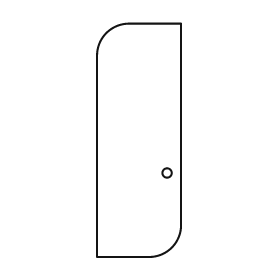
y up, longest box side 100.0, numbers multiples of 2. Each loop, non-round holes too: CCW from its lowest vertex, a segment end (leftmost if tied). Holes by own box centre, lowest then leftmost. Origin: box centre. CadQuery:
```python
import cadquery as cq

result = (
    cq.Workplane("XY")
    .moveTo(-18.0, -50.0)
    .lineTo(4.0, -50.0)
    .threePointArc((14.0, -46.0), (18.0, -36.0))
    .lineTo(18.0, 50.0)
    .lineTo(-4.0, 50.0)
    .threePointArc((-14.0, 46.0), (-18.0, 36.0))
    .close()
    .moveTo(12.0, -14.0)
    .circle(2.0)
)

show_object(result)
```